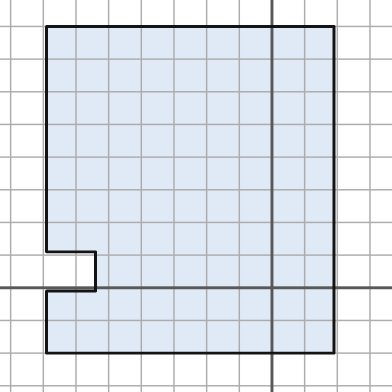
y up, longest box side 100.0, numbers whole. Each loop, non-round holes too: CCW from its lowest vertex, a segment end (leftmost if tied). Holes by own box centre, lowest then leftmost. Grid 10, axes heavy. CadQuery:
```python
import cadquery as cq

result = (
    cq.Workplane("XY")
    .moveTo(-69.0, -20.0)
    .lineTo(19.0, -20.0)
    .lineTo(19.0, 80.0)
    .lineTo(-69.0, 80.0)
    .lineTo(-69.0, 11.0)
    .lineTo(-54.0, 11.0)
    .lineTo(-54.0, -1.0)
    .lineTo(-69.0, -1.0)
    .close()
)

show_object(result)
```